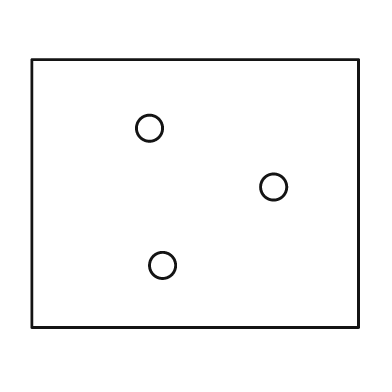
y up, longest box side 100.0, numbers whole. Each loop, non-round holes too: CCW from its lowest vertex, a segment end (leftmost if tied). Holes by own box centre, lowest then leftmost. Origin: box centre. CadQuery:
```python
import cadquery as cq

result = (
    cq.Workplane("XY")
    .moveTo(-50.0, -41.0)
    .lineTo(50.0, -41.0)
    .lineTo(50.0, 41.0)
    .lineTo(-50.0, 41.0)
    .close()
    .moveTo(-10.0, -22.0)
    .circle(4.0)
    .moveTo(24.0, 2.0)
    .circle(4.0)
    .moveTo(-14.0, 20.0)
    .circle(4.0)
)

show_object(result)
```